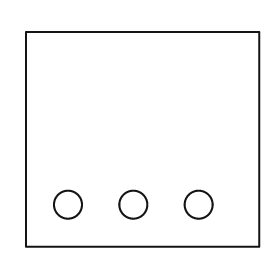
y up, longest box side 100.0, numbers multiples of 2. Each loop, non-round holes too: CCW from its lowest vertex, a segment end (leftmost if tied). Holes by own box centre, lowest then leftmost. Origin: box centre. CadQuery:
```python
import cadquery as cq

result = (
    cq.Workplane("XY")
    .moveTo(-50.0, -46.0)
    .lineTo(50.0, -46.0)
    .lineTo(50.0, 46.0)
    .lineTo(-50.0, 46.0)
    .close()
    .moveTo(-32.0, -28.0)
    .circle(6.0)
    .moveTo(-4.0, -28.0)
    .circle(6.0)
    .moveTo(24.0, -28.0)
    .circle(6.0)
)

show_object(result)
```